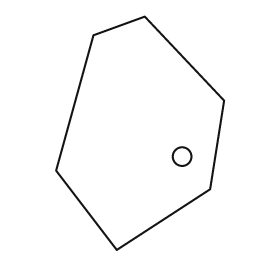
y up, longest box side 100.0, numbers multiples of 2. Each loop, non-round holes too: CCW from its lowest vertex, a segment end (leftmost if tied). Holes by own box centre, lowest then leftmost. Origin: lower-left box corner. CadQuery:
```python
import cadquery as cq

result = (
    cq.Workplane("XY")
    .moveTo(26.0, 0.0)
    .lineTo(66.0, 26.0)
    .lineTo(72.0, 64.0)
    .lineTo(38.0, 100.0)
    .lineTo(16.0, 92.0)
    .lineTo(0.0, 34.0)
    .close()
    .moveTo(54.0, 40.0)
    .circle(4.0)
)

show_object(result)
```